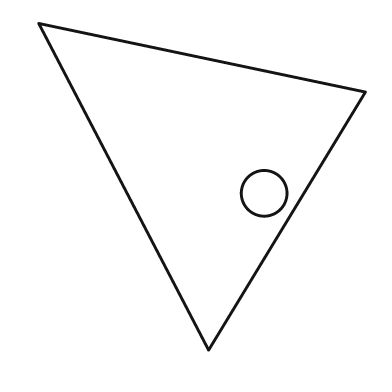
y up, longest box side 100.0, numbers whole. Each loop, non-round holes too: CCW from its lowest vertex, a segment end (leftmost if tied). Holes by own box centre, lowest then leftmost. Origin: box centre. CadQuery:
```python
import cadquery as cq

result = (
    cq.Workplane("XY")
    .moveTo(2.0, -50.0)
    .lineTo(50.0, 29.0)
    .lineTo(-50.0, 50.0)
    .close()
    .moveTo(19.0, -2.0)
    .circle(7.0)
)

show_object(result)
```